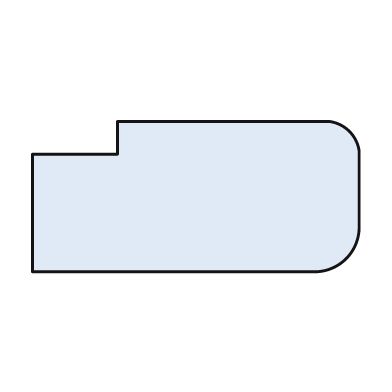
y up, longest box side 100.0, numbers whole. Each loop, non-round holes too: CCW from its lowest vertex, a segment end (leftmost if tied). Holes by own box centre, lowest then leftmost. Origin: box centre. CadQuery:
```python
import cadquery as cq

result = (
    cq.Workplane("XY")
    .moveTo(-50.0, -23.0)
    .lineTo(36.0, -23.0)
    .threePointArc((46.0, -19.0), (50.0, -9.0))
    .lineTo(50.0, 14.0)
    .threePointArc((47.0, 20.0), (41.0, 23.0))
    .lineTo(-24.0, 23.0)
    .lineTo(-24.0, 13.0)
    .lineTo(-50.0, 13.0)
    .close()
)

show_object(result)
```